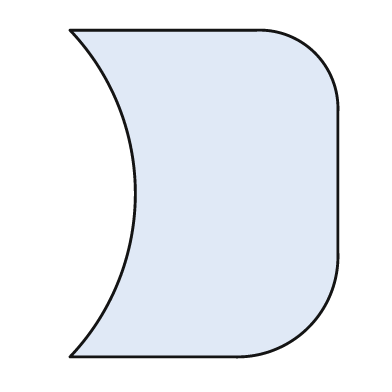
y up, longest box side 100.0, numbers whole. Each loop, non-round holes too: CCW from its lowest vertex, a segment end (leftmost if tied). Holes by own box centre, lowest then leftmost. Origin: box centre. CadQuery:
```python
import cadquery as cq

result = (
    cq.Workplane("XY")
    .moveTo(-41.0, -50.0)
    .lineTo(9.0, -50.0)
    .threePointArc((32.0, -41.0), (41.0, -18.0))
    .lineTo(41.0, 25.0)
    .threePointArc((34.0, 43.0), (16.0, 50.0))
    .lineTo(-41.0, 50.0)
    .threePointArc((-21.0, 0.0), (-41.0, -50.0))
    .close()
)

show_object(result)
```